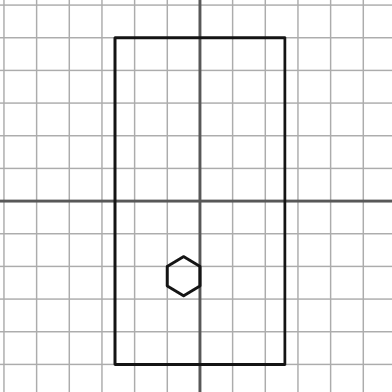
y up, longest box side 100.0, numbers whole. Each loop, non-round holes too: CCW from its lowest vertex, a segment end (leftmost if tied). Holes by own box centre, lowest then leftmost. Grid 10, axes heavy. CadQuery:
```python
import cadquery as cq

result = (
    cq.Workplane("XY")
    .moveTo(-26.0, -50.0)
    .lineTo(26.0, -50.0)
    .lineTo(26.0, 50.0)
    .lineTo(-26.0, 50.0)
    .close()
    .moveTo(-5.0, -29.0)
    .lineTo(0.0, -26.0)
    .lineTo(0.0, -20.0)
    .lineTo(-5.0, -17.0)
    .lineTo(-10.0, -20.0)
    .lineTo(-10.0, -26.0)
    .close()
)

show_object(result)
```